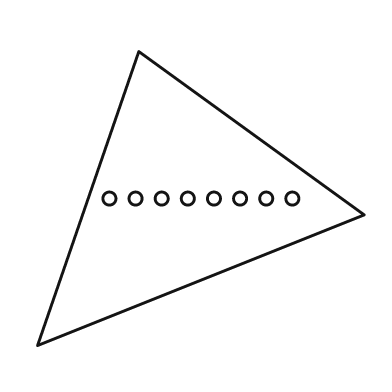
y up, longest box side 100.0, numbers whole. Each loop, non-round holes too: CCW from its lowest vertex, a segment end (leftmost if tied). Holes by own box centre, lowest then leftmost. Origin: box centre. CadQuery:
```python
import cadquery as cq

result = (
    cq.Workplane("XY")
    .moveTo(-50.0, -45.0)
    .lineTo(50.0, -5.0)
    .lineTo(-19.0, 45.0)
    .close()
    .moveTo(-28.0, 0.0)
    .circle(2.0)
    .moveTo(-20.0, 0.0)
    .circle(2.0)
    .moveTo(-12.0, 0.0)
    .circle(2.0)
    .moveTo(-4.0, 0.0)
    .circle(2.0)
    .moveTo(4.0, 0.0)
    .circle(2.0)
    .moveTo(12.0, 0.0)
    .circle(2.0)
    .moveTo(20.0, 0.0)
    .circle(2.0)
    .moveTo(28.0, 0.0)
    .circle(2.0)
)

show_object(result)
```